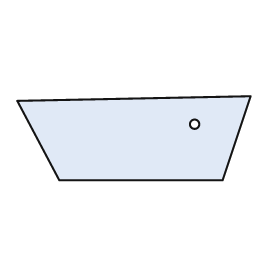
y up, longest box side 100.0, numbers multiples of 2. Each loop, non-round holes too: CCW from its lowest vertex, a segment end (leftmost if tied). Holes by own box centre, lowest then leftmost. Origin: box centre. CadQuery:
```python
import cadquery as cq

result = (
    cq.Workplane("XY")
    .moveTo(-32.0, -18.0)
    .lineTo(38.0, -18.0)
    .lineTo(50.0, 18.0)
    .lineTo(-50.0, 16.0)
    .close()
    .moveTo(26.0, 6.0)
    .circle(2.0)
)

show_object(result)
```